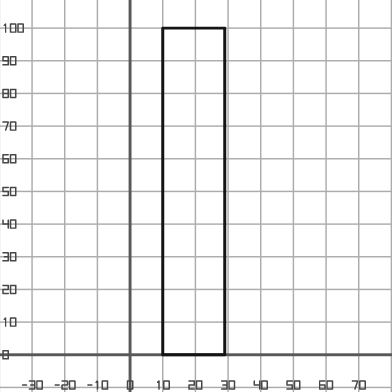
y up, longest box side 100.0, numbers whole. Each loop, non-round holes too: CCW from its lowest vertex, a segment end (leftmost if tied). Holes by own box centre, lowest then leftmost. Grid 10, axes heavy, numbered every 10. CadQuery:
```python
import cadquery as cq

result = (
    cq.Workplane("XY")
    .moveTo(10.0, 0.0)
    .lineTo(29.0, 0.0)
    .lineTo(29.0, 100.0)
    .lineTo(10.0, 100.0)
    .close()
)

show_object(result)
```